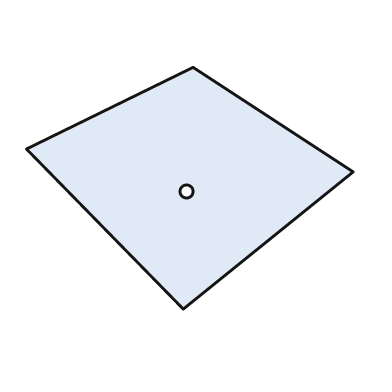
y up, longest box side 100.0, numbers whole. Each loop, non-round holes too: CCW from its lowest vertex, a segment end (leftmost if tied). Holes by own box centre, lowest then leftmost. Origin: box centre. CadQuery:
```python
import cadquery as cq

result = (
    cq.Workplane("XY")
    .moveTo(-2.0, -37.0)
    .lineTo(50.0, 5.0)
    .lineTo(1.0, 37.0)
    .lineTo(-50.0, 12.0)
    .close()
    .moveTo(-1.0, -1.0)
    .circle(2.0)
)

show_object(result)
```